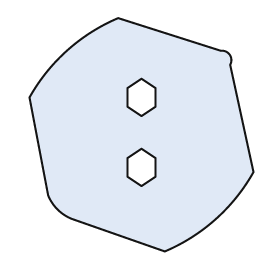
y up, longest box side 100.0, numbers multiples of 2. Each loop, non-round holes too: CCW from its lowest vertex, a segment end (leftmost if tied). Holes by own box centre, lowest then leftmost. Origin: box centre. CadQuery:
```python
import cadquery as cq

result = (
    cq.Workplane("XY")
    .moveTo(10.0, -50.0)
    .threePointArc((32.0, -36.0), (48.0, -16.0))
    .lineTo(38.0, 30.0)
    .threePointArc((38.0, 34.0), (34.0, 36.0))
    .lineTo(-10.0, 50.0)
    .threePointArc((-32.0, 36.0), (-48.0, 16.0))
    .lineTo(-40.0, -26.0)
    .threePointArc((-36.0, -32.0), (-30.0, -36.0))
    .close()
    .moveTo(0.0, -22.0)
    .lineTo(6.0, -18.0)
    .lineTo(6.0, -10.0)
    .lineTo(0.0, -6.0)
    .lineTo(-6.0, -10.0)
    .lineTo(-6.0, -18.0)
    .close()
    .moveTo(0.0, 8.0)
    .lineTo(6.0, 12.0)
    .lineTo(6.0, 20.0)
    .lineTo(0.0, 24.0)
    .lineTo(-6.0, 20.0)
    .lineTo(-6.0, 12.0)
    .close()
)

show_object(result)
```